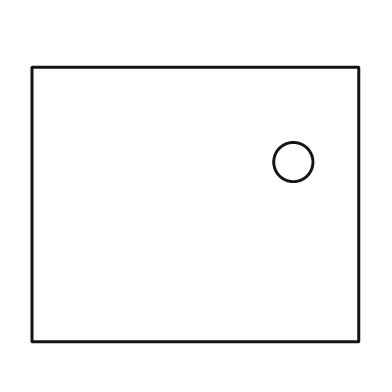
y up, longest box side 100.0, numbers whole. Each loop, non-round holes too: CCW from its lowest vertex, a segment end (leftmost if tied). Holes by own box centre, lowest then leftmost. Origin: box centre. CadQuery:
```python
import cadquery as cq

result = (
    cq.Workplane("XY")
    .moveTo(-50.0, -42.0)
    .lineTo(50.0, -42.0)
    .lineTo(50.0, 42.0)
    .lineTo(-50.0, 42.0)
    .close()
    .moveTo(30.0, 13.0)
    .circle(6.0)
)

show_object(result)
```